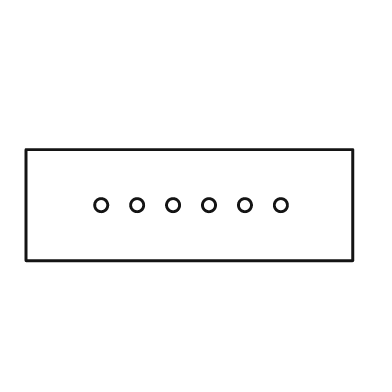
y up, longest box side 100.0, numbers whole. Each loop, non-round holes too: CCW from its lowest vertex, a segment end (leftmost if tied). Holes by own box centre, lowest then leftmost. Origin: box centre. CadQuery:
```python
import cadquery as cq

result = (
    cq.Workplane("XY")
    .moveTo(-50.0, -17.0)
    .lineTo(50.0, -17.0)
    .lineTo(50.0, 17.0)
    .lineTo(-50.0, 17.0)
    .close()
    .moveTo(-27.0, 0.0)
    .circle(2.0)
    .moveTo(-16.0, 0.0)
    .circle(2.0)
    .moveTo(-5.0, 0.0)
    .circle(2.0)
    .moveTo(6.0, 0.0)
    .circle(2.0)
    .moveTo(17.0, 0.0)
    .circle(2.0)
    .moveTo(28.0, 0.0)
    .circle(2.0)
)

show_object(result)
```